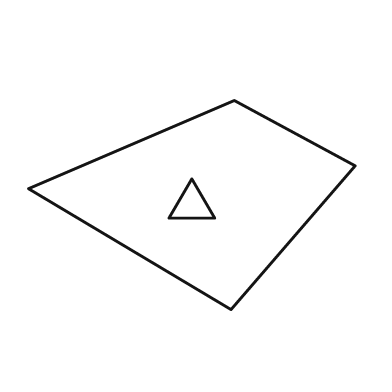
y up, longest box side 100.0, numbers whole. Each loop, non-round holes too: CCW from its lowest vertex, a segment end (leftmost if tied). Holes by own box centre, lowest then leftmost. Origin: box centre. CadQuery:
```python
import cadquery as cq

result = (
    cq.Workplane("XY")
    .moveTo(12.0, -32.0)
    .lineTo(50.0, 12.0)
    .lineTo(13.0, 32.0)
    .lineTo(-50.0, 5.0)
    .close()
    .moveTo(-7.0, -4.0)
    .lineTo(7.0, -4.0)
    .lineTo(0.0, 8.0)
    .close()
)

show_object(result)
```